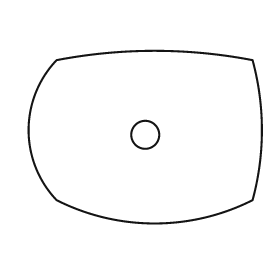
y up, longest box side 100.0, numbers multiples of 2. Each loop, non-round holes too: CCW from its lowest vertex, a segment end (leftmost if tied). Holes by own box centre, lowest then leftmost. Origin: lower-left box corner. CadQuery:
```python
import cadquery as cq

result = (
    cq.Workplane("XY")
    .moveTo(12.0, 10.0)
    .threePointArc((54.0, 0.0), (96.0, 10.0))
    .threePointArc((100.0, 40.0), (96.0, 70.0))
    .threePointArc((54.0, 74.0), (12.0, 70.0))
    .threePointArc((0.0, 40.0), (12.0, 10.0))
    .close()
    .moveTo(50.0, 38.0)
    .circle(6.0)
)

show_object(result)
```